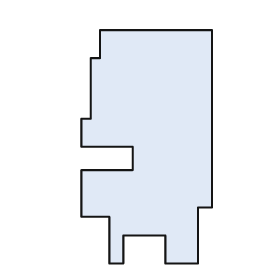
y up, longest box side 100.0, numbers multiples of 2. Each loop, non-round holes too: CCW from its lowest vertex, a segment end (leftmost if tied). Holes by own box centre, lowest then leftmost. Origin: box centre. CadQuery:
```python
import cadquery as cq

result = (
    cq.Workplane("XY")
    .moveTo(-16.0, -50.0)
    .lineTo(-10.0, -50.0)
    .lineTo(-10.0, -38.0)
    .lineTo(8.0, -38.0)
    .lineTo(8.0, -50.0)
    .lineTo(22.0, -50.0)
    .lineTo(22.0, -26.0)
    .lineTo(28.0, -26.0)
    .lineTo(28.0, 50.0)
    .lineTo(-20.0, 50.0)
    .lineTo(-20.0, 38.0)
    .lineTo(-24.0, 38.0)
    .lineTo(-24.0, 12.0)
    .lineTo(-28.0, 12.0)
    .lineTo(-28.0, 0.0)
    .lineTo(-6.0, 0.0)
    .lineTo(-6.0, -10.0)
    .lineTo(-28.0, -10.0)
    .lineTo(-28.0, -30.0)
    .lineTo(-16.0, -30.0)
    .close()
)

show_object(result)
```